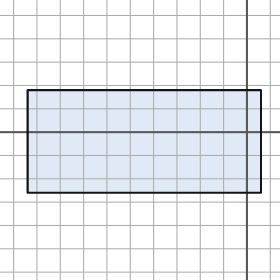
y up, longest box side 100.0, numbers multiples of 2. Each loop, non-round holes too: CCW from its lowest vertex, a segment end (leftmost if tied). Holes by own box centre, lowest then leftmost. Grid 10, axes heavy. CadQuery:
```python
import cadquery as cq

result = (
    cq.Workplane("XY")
    .moveTo(-94.0, -26.0)
    .lineTo(6.0, -26.0)
    .lineTo(6.0, 18.0)
    .lineTo(-94.0, 18.0)
    .close()
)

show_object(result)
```